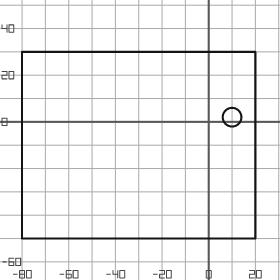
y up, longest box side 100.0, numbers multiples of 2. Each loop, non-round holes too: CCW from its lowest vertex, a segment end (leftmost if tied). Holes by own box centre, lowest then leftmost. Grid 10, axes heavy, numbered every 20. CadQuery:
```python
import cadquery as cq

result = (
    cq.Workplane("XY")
    .moveTo(-80.0, -50.0)
    .lineTo(20.0, -50.0)
    .lineTo(20.0, 30.0)
    .lineTo(-80.0, 30.0)
    .close()
    .moveTo(10.0, 2.0)
    .circle(4.0)
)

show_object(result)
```